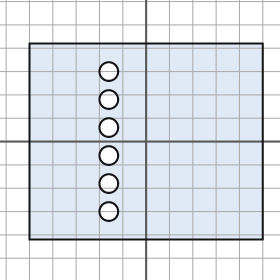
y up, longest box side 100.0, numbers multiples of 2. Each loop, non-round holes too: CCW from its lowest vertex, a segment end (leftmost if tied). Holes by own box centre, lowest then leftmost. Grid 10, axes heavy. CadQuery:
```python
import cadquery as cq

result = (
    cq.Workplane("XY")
    .moveTo(-50.0, -42.0)
    .lineTo(50.0, -42.0)
    .lineTo(50.0, 42.0)
    .lineTo(-50.0, 42.0)
    .close()
    .moveTo(-16.0, -30.0)
    .circle(4.0)
    .moveTo(-16.0, -18.0)
    .circle(4.0)
    .moveTo(-16.0, -6.0)
    .circle(4.0)
    .moveTo(-16.0, 6.0)
    .circle(4.0)
    .moveTo(-16.0, 18.0)
    .circle(4.0)
    .moveTo(-16.0, 30.0)
    .circle(4.0)
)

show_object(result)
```